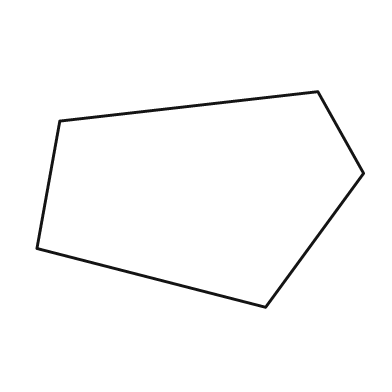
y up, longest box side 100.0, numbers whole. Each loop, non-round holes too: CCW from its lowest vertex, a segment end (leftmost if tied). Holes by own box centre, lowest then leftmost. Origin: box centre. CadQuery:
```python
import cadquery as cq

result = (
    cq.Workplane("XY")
    .moveTo(20.0, -33.0)
    .lineTo(50.0, 8.0)
    .lineTo(36.0, 33.0)
    .lineTo(-43.0, 24.0)
    .lineTo(-50.0, -15.0)
    .close()
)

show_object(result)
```